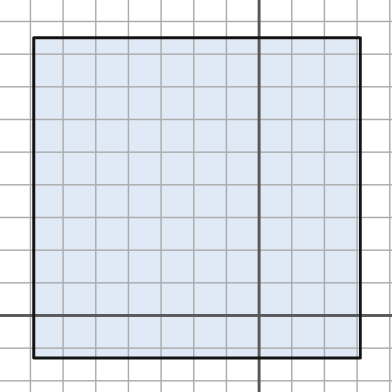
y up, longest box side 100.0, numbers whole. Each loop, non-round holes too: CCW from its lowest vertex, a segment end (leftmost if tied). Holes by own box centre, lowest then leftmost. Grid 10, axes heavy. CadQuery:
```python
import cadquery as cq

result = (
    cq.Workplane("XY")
    .moveTo(-69.0, -13.0)
    .lineTo(31.0, -13.0)
    .lineTo(31.0, 85.0)
    .lineTo(-69.0, 85.0)
    .close()
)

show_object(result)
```